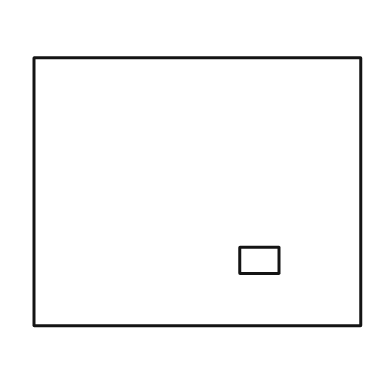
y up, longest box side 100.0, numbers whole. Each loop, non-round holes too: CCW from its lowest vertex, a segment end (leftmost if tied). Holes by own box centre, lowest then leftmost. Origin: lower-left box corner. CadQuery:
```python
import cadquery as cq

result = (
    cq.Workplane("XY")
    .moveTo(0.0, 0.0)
    .lineTo(100.0, 0.0)
    .lineTo(100.0, 82.0)
    .lineTo(0.0, 82.0)
    .close()
    .moveTo(63.0, 16.0)
    .lineTo(75.0, 16.0)
    .lineTo(75.0, 24.0)
    .lineTo(63.0, 24.0)
    .close()
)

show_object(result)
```